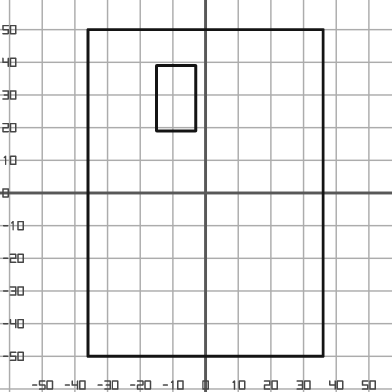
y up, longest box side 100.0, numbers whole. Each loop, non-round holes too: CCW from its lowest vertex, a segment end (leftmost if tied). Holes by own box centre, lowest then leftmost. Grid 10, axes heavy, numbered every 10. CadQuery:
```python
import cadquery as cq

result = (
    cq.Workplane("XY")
    .moveTo(-36.0, -50.0)
    .lineTo(36.0, -50.0)
    .lineTo(36.0, 50.0)
    .lineTo(-36.0, 50.0)
    .close()
    .moveTo(-15.0, 19.0)
    .lineTo(-3.0, 19.0)
    .lineTo(-3.0, 39.0)
    .lineTo(-15.0, 39.0)
    .close()
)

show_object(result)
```